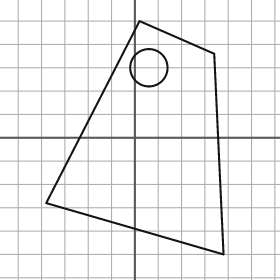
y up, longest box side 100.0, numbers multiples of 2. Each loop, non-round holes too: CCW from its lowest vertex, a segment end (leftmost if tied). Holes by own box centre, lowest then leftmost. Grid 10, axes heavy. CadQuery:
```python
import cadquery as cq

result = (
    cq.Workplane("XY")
    .moveTo(38.0, -50.0)
    .lineTo(34.0, 36.0)
    .lineTo(2.0, 50.0)
    .lineTo(-38.0, -28.0)
    .close()
    .moveTo(6.0, 30.0)
    .circle(8.0)
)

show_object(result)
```